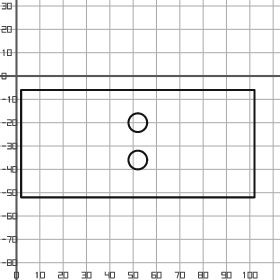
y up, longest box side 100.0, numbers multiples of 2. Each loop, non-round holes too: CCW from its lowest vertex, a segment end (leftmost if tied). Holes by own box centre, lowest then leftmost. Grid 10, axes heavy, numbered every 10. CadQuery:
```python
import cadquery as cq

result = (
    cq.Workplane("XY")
    .moveTo(2.0, -52.0)
    .lineTo(102.0, -52.0)
    .lineTo(102.0, -6.0)
    .lineTo(2.0, -6.0)
    .close()
    .moveTo(52.0, -36.0)
    .circle(4.0)
    .moveTo(52.0, -20.0)
    .circle(4.0)
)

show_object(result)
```